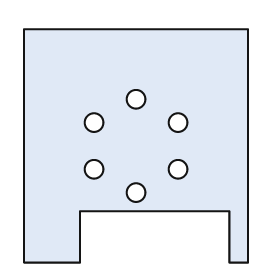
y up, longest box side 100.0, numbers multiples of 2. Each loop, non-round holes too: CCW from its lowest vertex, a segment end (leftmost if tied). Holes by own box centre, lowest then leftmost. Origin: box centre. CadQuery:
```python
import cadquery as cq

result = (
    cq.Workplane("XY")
    .moveTo(-48.0, -50.0)
    .lineTo(-24.0, -50.0)
    .lineTo(-24.0, -28.0)
    .lineTo(40.0, -28.0)
    .lineTo(40.0, -50.0)
    .lineTo(48.0, -50.0)
    .lineTo(48.0, 50.0)
    .lineTo(-48.0, 50.0)
    .close()
    .moveTo(0.0, -20.0)
    .circle(4.0)
    .moveTo(-18.0, -10.0)
    .circle(4.0)
    .moveTo(18.0, -10.0)
    .circle(4.0)
    .moveTo(-18.0, 10.0)
    .circle(4.0)
    .moveTo(18.0, 10.0)
    .circle(4.0)
    .moveTo(0.0, 20.0)
    .circle(4.0)
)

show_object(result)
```